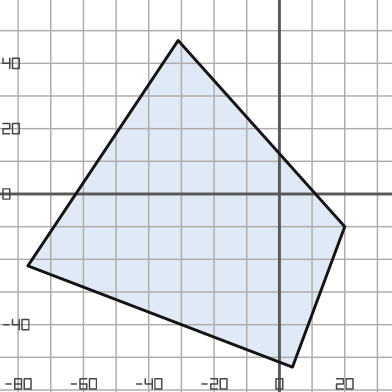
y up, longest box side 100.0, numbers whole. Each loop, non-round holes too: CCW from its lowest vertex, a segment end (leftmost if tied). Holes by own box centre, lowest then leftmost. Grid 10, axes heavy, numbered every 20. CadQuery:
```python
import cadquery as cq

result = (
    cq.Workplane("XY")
    .moveTo(4.0, -53.0)
    .lineTo(20.0, -10.0)
    .lineTo(-31.0, 47.0)
    .lineTo(-77.0, -22.0)
    .close()
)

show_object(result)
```